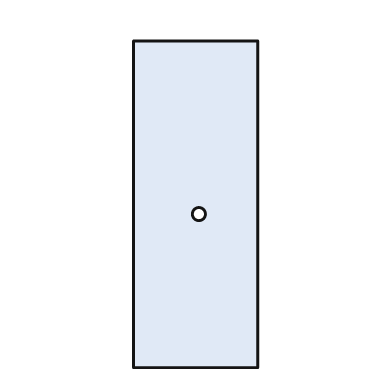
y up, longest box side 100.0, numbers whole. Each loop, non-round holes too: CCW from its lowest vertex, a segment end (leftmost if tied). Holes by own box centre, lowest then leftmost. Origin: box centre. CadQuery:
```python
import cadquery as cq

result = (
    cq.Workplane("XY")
    .moveTo(-19.0, -50.0)
    .lineTo(19.0, -50.0)
    .lineTo(19.0, 50.0)
    .lineTo(-19.0, 50.0)
    .close()
    .moveTo(1.0, -3.0)
    .circle(2.0)
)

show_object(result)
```